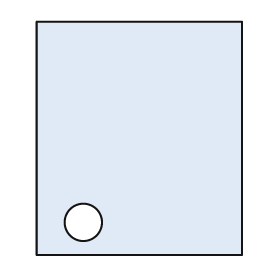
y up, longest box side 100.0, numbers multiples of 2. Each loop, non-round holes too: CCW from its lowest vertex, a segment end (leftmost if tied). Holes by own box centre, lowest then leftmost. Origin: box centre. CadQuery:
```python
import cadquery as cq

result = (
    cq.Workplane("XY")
    .moveTo(-44.0, -50.0)
    .lineTo(44.0, -50.0)
    .lineTo(44.0, 50.0)
    .lineTo(-44.0, 50.0)
    .close()
    .moveTo(-24.0, -36.0)
    .circle(8.0)
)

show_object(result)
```